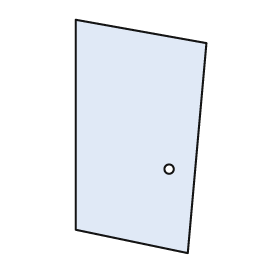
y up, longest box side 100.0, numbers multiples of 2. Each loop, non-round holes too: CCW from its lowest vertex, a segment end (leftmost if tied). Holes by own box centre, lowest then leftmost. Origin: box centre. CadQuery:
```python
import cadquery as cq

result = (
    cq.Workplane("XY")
    .moveTo(20.0, -50.0)
    .lineTo(28.0, 40.0)
    .lineTo(-28.0, 50.0)
    .lineTo(-28.0, -40.0)
    .close()
    .moveTo(12.0, -14.0)
    .circle(2.0)
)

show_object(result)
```